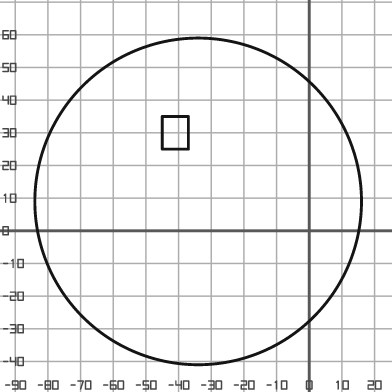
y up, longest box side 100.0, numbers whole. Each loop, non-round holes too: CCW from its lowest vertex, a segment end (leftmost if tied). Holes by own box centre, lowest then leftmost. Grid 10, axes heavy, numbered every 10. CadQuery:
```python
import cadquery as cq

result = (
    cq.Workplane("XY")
    .moveTo(-34.0, 9.0)
    .circle(50.0)
    .moveTo(-45.0, 25.0)
    .lineTo(-37.0, 25.0)
    .lineTo(-37.0, 35.0)
    .lineTo(-45.0, 35.0)
    .close()
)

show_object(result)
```